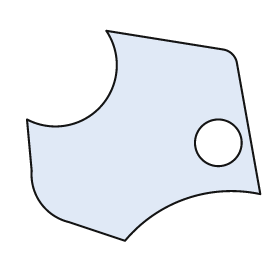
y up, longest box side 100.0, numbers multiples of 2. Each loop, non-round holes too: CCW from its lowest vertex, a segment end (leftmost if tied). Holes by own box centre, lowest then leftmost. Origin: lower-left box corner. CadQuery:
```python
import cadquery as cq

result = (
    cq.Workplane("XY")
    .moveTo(42.0, 0.0)
    .threePointArc((68.0, 18.0), (100.0, 20.0))
    .lineTo(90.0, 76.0)
    .threePointArc((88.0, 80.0), (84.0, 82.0))
    .lineTo(34.0, 90.0)
    .threePointArc((32.0, 58.0), (0.0, 52.0))
    .lineTo(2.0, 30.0)
    .threePointArc((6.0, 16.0), (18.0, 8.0))
    .close()
    .moveTo(82.0, 42.0)
    .circle(10.0)
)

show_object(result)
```